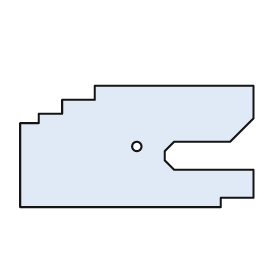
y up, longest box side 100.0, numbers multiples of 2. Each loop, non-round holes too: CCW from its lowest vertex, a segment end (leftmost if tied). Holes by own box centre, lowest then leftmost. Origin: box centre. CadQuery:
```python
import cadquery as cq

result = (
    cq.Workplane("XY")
    .moveTo(-50.0, -26.0)
    .lineTo(36.0, -26.0)
    .lineTo(36.0, -22.0)
    .lineTo(50.0, -22.0)
    .lineTo(50.0, -10.0)
    .lineTo(16.0, -10.0)
    .lineTo(12.0, -6.0)
    .lineTo(12.0, -2.0)
    .lineTo(16.0, 2.0)
    .lineTo(40.0, 2.0)
    .lineTo(50.0, 12.0)
    .lineTo(50.0, 26.0)
    .lineTo(-18.0, 26.0)
    .lineTo(-18.0, 20.0)
    .lineTo(-32.0, 20.0)
    .lineTo(-32.0, 14.0)
    .lineTo(-42.0, 14.0)
    .lineTo(-42.0, 10.0)
    .lineTo(-50.0, 10.0)
    .close()
    .moveTo(0.0, 0.0)
    .circle(2.0)
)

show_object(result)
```